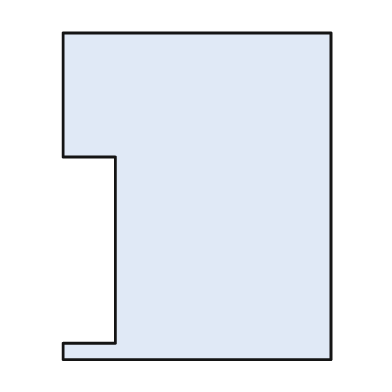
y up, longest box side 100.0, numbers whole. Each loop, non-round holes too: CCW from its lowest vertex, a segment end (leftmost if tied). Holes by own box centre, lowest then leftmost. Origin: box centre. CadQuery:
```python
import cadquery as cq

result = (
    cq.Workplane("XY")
    .moveTo(-41.0, -50.0)
    .lineTo(41.0, -50.0)
    .lineTo(41.0, 50.0)
    .lineTo(-41.0, 50.0)
    .lineTo(-41.0, 12.0)
    .lineTo(-25.0, 12.0)
    .lineTo(-25.0, -45.0)
    .lineTo(-41.0, -45.0)
    .close()
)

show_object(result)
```